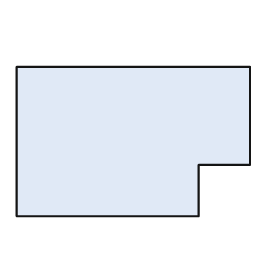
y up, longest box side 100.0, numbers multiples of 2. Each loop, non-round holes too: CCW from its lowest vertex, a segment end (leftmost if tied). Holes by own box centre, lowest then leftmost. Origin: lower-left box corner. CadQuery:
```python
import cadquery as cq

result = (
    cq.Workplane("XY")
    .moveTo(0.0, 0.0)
    .lineTo(78.0, 0.0)
    .lineTo(78.0, 22.0)
    .lineTo(100.0, 22.0)
    .lineTo(100.0, 64.0)
    .lineTo(0.0, 64.0)
    .close()
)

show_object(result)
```